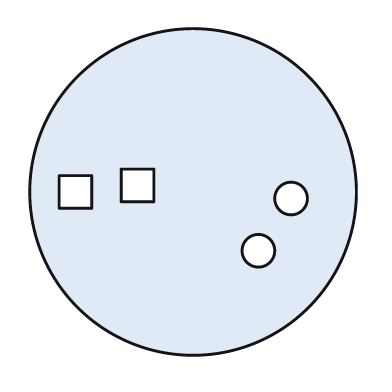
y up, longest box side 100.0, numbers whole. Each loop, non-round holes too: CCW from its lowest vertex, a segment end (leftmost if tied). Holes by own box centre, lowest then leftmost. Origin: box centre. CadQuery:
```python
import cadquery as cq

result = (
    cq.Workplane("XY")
    .moveTo(0.0, 0.0)
    .circle(50.0)
    .moveTo(20.0, -18.0)
    .circle(5.0)
    .moveTo(30.0, -2.0)
    .circle(5.0)
    .moveTo(-41.0, -5.0)
    .lineTo(-31.0, -5.0)
    .lineTo(-31.0, 5.0)
    .lineTo(-41.0, 5.0)
    .close()
    .moveTo(-22.0, -3.0)
    .lineTo(-12.0, -3.0)
    .lineTo(-12.0, 7.0)
    .lineTo(-22.0, 7.0)
    .close()
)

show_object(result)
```